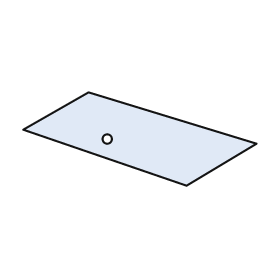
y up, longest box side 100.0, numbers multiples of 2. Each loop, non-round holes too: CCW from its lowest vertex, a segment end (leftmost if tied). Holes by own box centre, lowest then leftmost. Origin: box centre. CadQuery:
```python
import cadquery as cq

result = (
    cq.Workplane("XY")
    .moveTo(20.0, -20.0)
    .lineTo(50.0, -2.0)
    .lineTo(-22.0, 20.0)
    .lineTo(-50.0, 4.0)
    .close()
    .moveTo(-14.0, 0.0)
    .circle(2.0)
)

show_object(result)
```